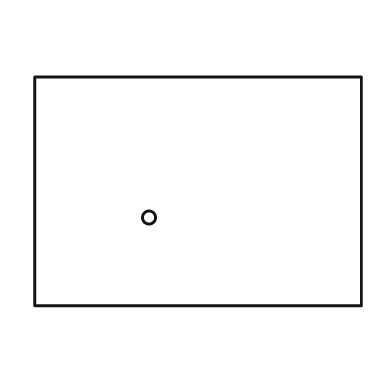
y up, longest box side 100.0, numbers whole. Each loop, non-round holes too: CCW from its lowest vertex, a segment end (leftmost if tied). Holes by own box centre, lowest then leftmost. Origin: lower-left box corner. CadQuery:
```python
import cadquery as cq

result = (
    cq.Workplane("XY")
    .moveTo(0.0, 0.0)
    .lineTo(100.0, 0.0)
    .lineTo(100.0, 70.0)
    .lineTo(0.0, 70.0)
    .close()
    .moveTo(35.0, 27.0)
    .circle(2.0)
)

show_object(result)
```